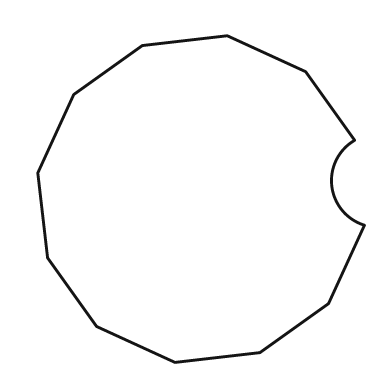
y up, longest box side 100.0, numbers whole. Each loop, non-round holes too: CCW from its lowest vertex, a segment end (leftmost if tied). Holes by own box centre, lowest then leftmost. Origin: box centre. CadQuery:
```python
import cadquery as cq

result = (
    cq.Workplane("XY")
    .moveTo(-8.0, -50.0)
    .lineTo(18.0, -47.0)
    .lineTo(39.0, -32.0)
    .lineTo(50.0, -8.0)
    .threePointArc((40.0, 4.0), (47.0, 18.0))
    .lineTo(32.0, 39.0)
    .lineTo(8.0, 50.0)
    .lineTo(-18.0, 47.0)
    .lineTo(-39.0, 32.0)
    .lineTo(-50.0, 8.0)
    .lineTo(-47.0, -18.0)
    .lineTo(-32.0, -39.0)
    .close()
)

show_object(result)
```